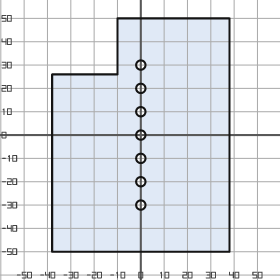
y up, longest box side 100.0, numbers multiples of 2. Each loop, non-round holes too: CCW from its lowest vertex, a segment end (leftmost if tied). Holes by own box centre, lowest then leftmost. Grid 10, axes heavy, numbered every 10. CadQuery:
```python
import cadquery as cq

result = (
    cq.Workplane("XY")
    .moveTo(-38.0, -50.0)
    .lineTo(38.0, -50.0)
    .lineTo(38.0, 50.0)
    .lineTo(-10.0, 50.0)
    .lineTo(-10.0, 26.0)
    .lineTo(-38.0, 26.0)
    .close()
    .moveTo(0.0, -30.0)
    .circle(2.0)
    .moveTo(0.0, -20.0)
    .circle(2.0)
    .moveTo(0.0, -10.0)
    .circle(2.0)
    .moveTo(0.0, 0.0)
    .circle(2.0)
    .moveTo(0.0, 10.0)
    .circle(2.0)
    .moveTo(0.0, 20.0)
    .circle(2.0)
    .moveTo(0.0, 30.0)
    .circle(2.0)
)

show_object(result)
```